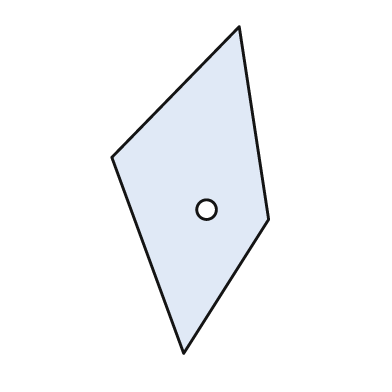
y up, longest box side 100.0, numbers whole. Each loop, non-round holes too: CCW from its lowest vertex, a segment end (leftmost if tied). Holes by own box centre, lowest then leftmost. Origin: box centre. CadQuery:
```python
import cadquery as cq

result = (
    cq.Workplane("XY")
    .moveTo(-2.0, -50.0)
    .lineTo(24.0, -9.0)
    .lineTo(15.0, 50.0)
    .lineTo(-24.0, 10.0)
    .close()
    .moveTo(5.0, -6.0)
    .circle(3.0)
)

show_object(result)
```